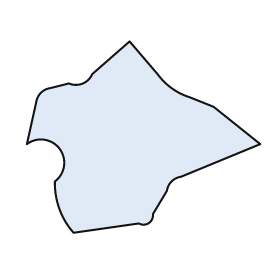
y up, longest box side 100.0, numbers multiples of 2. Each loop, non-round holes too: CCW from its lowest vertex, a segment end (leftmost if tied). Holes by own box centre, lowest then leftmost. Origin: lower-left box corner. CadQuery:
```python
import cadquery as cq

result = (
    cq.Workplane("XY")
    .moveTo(20.0, 0.0)
    .lineTo(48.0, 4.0)
    .threePointArc((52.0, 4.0), (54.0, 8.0))
    .lineTo(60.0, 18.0)
    .threePointArc((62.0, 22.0), (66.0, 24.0))
    .lineTo(100.0, 38.0)
    .lineTo(80.0, 54.0)
    .lineTo(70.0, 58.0)
    .threePointArc((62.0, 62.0), (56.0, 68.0))
    .lineTo(44.0, 82.0)
    .lineTo(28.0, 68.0)
    .threePointArc((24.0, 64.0), (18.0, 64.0))
    .lineTo(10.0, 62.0)
    .threePointArc((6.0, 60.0), (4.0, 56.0))
    .lineTo(0.0, 38.0)
    .threePointArc((14.0, 36.0), (12.0, 22.0))
    .threePointArc((14.0, 10.0), (20.0, 0.0))
    .close()
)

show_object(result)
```